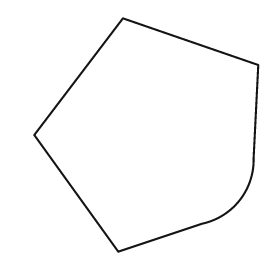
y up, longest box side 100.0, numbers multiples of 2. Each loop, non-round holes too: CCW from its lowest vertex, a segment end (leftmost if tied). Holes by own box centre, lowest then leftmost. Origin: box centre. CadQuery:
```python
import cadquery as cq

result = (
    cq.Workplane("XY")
    .moveTo(-12.0, -50.0)
    .lineTo(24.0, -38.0)
    .threePointArc((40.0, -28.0), (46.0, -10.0))
    .lineTo(48.0, 30.0)
    .lineTo(-10.0, 50.0)
    .lineTo(-48.0, 0.0)
    .close()
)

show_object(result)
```